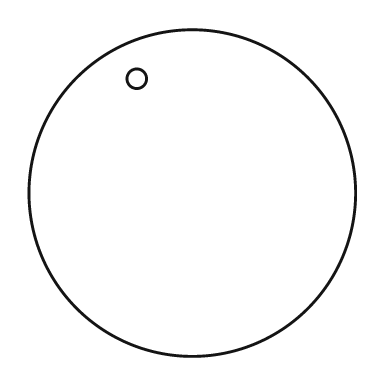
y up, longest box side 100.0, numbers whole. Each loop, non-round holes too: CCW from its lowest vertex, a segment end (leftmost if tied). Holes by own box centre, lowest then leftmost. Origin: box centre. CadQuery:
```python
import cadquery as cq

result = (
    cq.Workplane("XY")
    .moveTo(0.0, 0.0)
    .circle(50.0)
    .moveTo(-17.0, 35.0)
    .circle(3.0)
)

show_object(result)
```